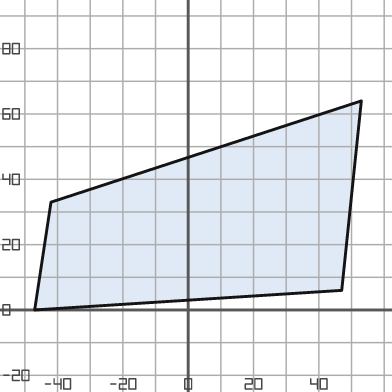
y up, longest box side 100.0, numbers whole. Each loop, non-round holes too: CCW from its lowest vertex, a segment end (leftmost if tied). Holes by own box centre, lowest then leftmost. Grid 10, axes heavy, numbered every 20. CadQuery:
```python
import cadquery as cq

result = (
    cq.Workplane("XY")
    .moveTo(-47.0, 0.0)
    .lineTo(47.0, 6.0)
    .lineTo(53.0, 64.0)
    .lineTo(-42.0, 33.0)
    .close()
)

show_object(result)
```